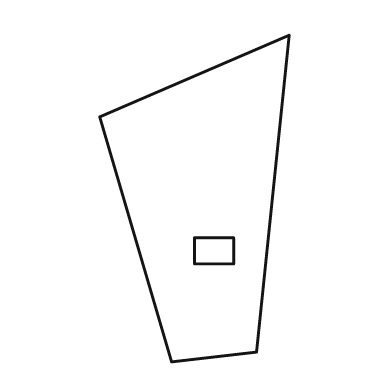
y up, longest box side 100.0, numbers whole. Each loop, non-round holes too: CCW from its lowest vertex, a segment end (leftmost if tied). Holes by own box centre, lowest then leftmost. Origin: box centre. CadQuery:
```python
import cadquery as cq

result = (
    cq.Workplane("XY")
    .moveTo(-7.0, -50.0)
    .lineTo(19.0, -47.0)
    .lineTo(29.0, 50.0)
    .lineTo(-29.0, 25.0)
    .close()
    .moveTo(0.0, -20.0)
    .lineTo(12.0, -20.0)
    .lineTo(12.0, -12.0)
    .lineTo(0.0, -12.0)
    .close()
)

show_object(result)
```